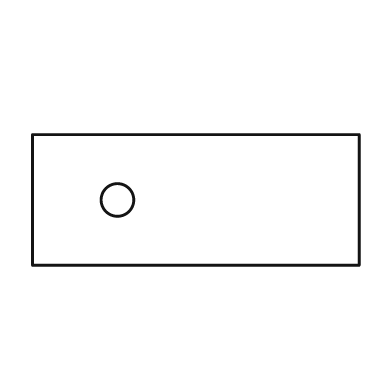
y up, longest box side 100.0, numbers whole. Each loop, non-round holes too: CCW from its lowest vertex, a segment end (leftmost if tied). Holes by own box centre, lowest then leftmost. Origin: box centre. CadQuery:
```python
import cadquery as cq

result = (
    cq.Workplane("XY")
    .moveTo(-50.0, -20.0)
    .lineTo(50.0, -20.0)
    .lineTo(50.0, 20.0)
    .lineTo(-50.0, 20.0)
    .close()
    .moveTo(-24.0, 0.0)
    .circle(5.0)
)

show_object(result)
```